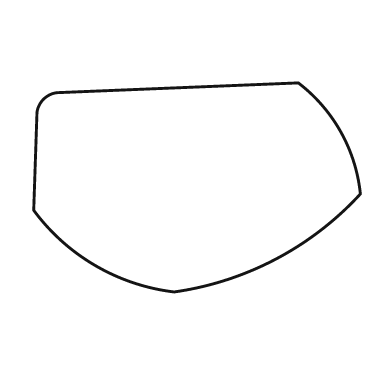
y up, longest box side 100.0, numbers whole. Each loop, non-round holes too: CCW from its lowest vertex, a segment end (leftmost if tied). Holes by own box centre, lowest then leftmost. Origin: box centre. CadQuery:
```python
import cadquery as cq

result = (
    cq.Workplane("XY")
    .moveTo(-7.0, -32.0)
    .threePointArc((24.0, -22.0), (50.0, -2.0))
    .threePointArc((44.0, 17.0), (31.0, 32.0))
    .lineTo(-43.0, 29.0)
    .threePointArc((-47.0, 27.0), (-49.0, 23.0))
    .lineTo(-50.0, -7.0)
    .threePointArc((-31.0, -24.0), (-7.0, -32.0))
    .close()
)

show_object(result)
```